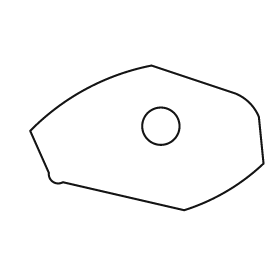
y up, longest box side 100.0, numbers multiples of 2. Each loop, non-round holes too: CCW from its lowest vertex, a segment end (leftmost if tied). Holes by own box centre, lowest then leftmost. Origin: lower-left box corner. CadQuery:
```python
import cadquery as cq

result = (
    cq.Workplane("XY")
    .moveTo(66.0, 0.0)
    .threePointArc((84.0, 8.0), (100.0, 20.0))
    .lineTo(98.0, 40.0)
    .threePointArc((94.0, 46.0), (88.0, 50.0))
    .lineTo(52.0, 62.0)
    .threePointArc((24.0, 52.0), (0.0, 34.0))
    .lineTo(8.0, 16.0)
    .threePointArc((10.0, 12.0), (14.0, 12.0))
    .close()
    .moveTo(56.0, 36.0)
    .circle(8.0)
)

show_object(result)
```